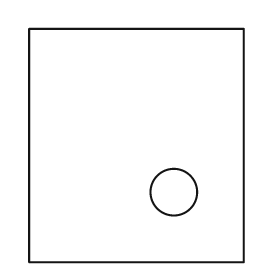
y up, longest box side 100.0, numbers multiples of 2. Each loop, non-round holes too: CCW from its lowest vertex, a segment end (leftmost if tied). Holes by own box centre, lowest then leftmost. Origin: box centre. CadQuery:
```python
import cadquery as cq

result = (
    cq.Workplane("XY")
    .moveTo(-46.0, -50.0)
    .lineTo(46.0, -50.0)
    .lineTo(46.0, 50.0)
    .lineTo(-46.0, 50.0)
    .close()
    .moveTo(16.0, -20.0)
    .circle(10.0)
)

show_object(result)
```